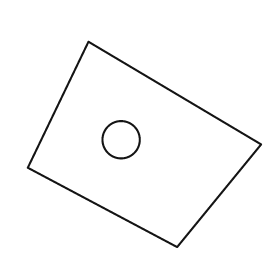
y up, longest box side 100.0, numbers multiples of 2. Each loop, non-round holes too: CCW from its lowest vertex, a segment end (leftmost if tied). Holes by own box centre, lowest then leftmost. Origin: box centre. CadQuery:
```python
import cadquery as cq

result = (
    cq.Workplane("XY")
    .moveTo(14.0, -44.0)
    .lineTo(50.0, 0.0)
    .lineTo(-24.0, 44.0)
    .lineTo(-50.0, -10.0)
    .close()
    .moveTo(-10.0, 2.0)
    .circle(8.0)
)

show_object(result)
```